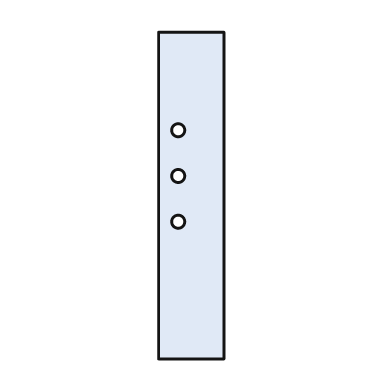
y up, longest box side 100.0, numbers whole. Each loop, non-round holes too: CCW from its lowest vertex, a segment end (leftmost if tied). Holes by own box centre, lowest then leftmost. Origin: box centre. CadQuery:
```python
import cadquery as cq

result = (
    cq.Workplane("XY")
    .moveTo(-10.0, -50.0)
    .lineTo(10.0, -50.0)
    .lineTo(10.0, 50.0)
    .lineTo(-10.0, 50.0)
    .close()
    .moveTo(-4.0, -8.0)
    .circle(2.0)
    .moveTo(-4.0, 6.0)
    .circle(2.0)
    .moveTo(-4.0, 20.0)
    .circle(2.0)
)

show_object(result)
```